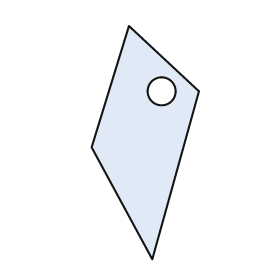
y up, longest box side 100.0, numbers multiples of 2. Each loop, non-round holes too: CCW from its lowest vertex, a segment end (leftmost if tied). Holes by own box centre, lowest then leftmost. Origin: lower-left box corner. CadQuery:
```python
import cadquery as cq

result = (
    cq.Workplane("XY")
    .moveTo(26.0, 0.0)
    .lineTo(46.0, 72.0)
    .lineTo(16.0, 100.0)
    .lineTo(0.0, 48.0)
    .close()
    .moveTo(30.0, 72.0)
    .circle(6.0)
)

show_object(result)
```